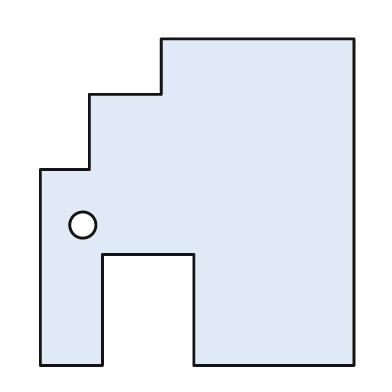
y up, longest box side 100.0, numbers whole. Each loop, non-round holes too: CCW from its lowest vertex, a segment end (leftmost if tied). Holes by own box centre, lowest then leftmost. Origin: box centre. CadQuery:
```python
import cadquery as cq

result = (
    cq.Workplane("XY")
    .moveTo(-48.0, -50.0)
    .lineTo(-29.0, -50.0)
    .lineTo(-29.0, -16.0)
    .lineTo(-1.0, -16.0)
    .lineTo(-1.0, -50.0)
    .lineTo(48.0, -50.0)
    .lineTo(48.0, 50.0)
    .lineTo(-11.0, 50.0)
    .lineTo(-11.0, 33.0)
    .lineTo(-33.0, 33.0)
    .lineTo(-33.0, 10.0)
    .lineTo(-48.0, 10.0)
    .close()
    .moveTo(-35.0, -7.0)
    .circle(4.0)
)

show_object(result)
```